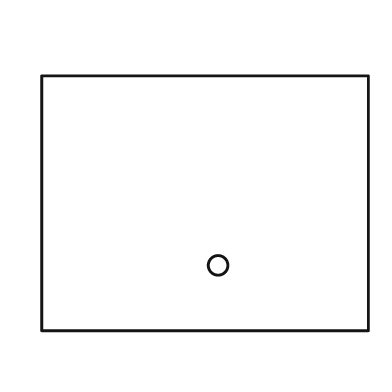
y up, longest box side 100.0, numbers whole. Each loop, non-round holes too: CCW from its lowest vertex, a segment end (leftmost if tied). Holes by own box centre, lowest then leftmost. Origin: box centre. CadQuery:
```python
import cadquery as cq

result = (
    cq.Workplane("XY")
    .moveTo(-50.0, -39.0)
    .lineTo(50.0, -39.0)
    .lineTo(50.0, 39.0)
    .lineTo(-50.0, 39.0)
    .close()
    .moveTo(4.0, -19.0)
    .circle(3.0)
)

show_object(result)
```